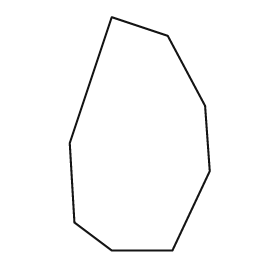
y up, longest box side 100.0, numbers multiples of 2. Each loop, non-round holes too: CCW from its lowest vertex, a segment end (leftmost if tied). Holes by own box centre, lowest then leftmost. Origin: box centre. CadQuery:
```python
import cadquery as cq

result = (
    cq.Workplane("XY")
    .moveTo(-12.0, -50.0)
    .lineTo(14.0, -50.0)
    .lineTo(30.0, -16.0)
    .lineTo(28.0, 12.0)
    .lineTo(12.0, 42.0)
    .lineTo(-12.0, 50.0)
    .lineTo(-30.0, -4.0)
    .lineTo(-28.0, -38.0)
    .close()
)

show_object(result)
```